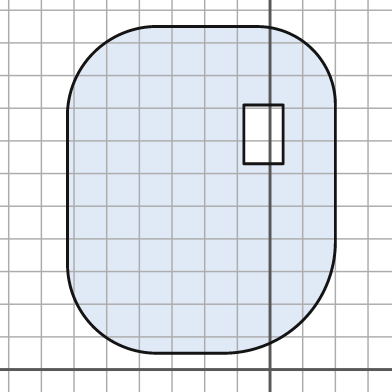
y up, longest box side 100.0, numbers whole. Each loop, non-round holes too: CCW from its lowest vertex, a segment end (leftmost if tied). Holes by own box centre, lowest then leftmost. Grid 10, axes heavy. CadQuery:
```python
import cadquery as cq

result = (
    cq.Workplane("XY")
    .moveTo(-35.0, 5.0)
    .lineTo(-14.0, 5.0)
    .threePointArc((10.0, 15.0), (20.0, 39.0))
    .lineTo(20.0, 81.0)
    .threePointArc((13.0, 98.0), (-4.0, 105.0))
    .lineTo(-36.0, 105.0)
    .threePointArc((-54.0, 97.0), (-62.0, 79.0))
    .lineTo(-62.0, 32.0)
    .threePointArc((-54.0, 13.0), (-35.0, 5.0))
    .close()
    .moveTo(-8.0, 63.0)
    .lineTo(4.0, 63.0)
    .lineTo(4.0, 81.0)
    .lineTo(-8.0, 81.0)
    .close()
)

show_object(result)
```